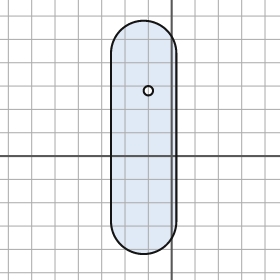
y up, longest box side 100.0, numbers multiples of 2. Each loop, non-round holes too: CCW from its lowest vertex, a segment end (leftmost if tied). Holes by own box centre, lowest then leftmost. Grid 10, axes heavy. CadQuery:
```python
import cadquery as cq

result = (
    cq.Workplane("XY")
    .moveTo(-26.0, -28.0)
    .threePointArc((-12.0, -42.0), (2.0, -28.0))
    .lineTo(2.0, 44.0)
    .threePointArc((-12.0, 58.0), (-26.0, 44.0))
    .close()
    .moveTo(-10.0, 28.0)
    .circle(2.0)
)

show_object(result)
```